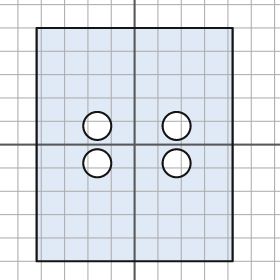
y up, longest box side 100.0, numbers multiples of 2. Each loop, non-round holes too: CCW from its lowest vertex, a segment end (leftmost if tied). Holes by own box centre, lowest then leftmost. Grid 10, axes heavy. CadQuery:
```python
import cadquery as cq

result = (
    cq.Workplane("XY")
    .moveTo(-42.0, -50.0)
    .lineTo(42.0, -50.0)
    .lineTo(42.0, 50.0)
    .lineTo(-42.0, 50.0)
    .close()
    .moveTo(-16.0, -8.0)
    .circle(6.0)
    .moveTo(18.0, -8.0)
    .circle(6.0)
    .moveTo(-16.0, 8.0)
    .circle(6.0)
    .moveTo(18.0, 8.0)
    .circle(6.0)
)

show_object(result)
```